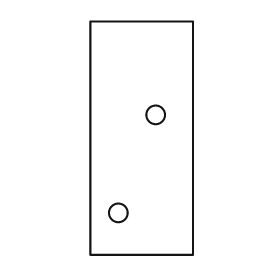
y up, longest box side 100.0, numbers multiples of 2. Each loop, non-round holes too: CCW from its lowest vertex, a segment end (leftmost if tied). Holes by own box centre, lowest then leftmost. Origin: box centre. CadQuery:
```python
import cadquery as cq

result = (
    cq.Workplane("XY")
    .moveTo(-22.0, -50.0)
    .lineTo(22.0, -50.0)
    .lineTo(22.0, 50.0)
    .lineTo(-22.0, 50.0)
    .close()
    .moveTo(-10.0, -32.0)
    .circle(4.0)
    .moveTo(6.0, 10.0)
    .circle(4.0)
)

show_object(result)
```